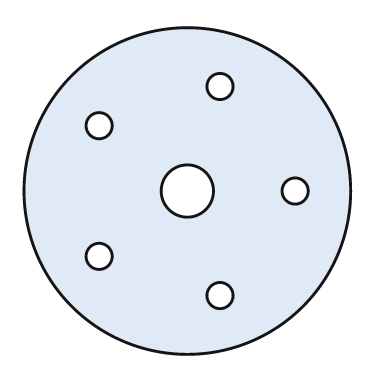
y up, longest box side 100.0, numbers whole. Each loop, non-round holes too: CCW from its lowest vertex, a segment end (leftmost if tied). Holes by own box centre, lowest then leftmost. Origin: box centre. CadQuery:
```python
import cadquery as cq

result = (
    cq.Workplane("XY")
    .moveTo(0.0, 0.0)
    .circle(50.0)
    .moveTo(10.0, -32.0)
    .circle(4.0)
    .moveTo(-27.0, -20.0)
    .circle(4.0)
    .moveTo(0.0, 0.0)
    .circle(8.0)
    .moveTo(33.0, 0.0)
    .circle(4.0)
    .moveTo(-27.0, 20.0)
    .circle(4.0)
    .moveTo(10.0, 32.0)
    .circle(4.0)
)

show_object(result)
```